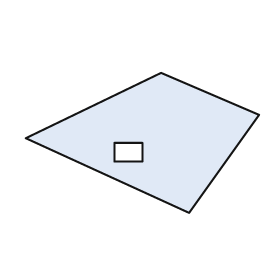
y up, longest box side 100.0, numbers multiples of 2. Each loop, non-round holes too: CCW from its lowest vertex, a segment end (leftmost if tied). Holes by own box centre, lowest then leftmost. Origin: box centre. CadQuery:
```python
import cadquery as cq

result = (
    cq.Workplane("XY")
    .moveTo(20.0, -30.0)
    .lineTo(50.0, 12.0)
    .lineTo(8.0, 30.0)
    .lineTo(-50.0, 2.0)
    .close()
    .moveTo(-12.0, -8.0)
    .lineTo(0.0, -8.0)
    .lineTo(0.0, 0.0)
    .lineTo(-12.0, 0.0)
    .close()
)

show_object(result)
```